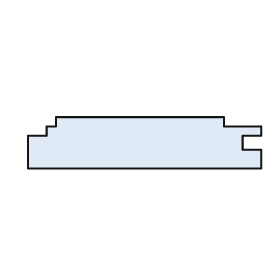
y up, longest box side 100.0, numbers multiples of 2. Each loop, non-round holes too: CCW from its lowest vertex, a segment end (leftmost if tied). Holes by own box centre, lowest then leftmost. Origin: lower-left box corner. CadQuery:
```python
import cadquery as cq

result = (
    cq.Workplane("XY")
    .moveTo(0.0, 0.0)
    .lineTo(100.0, 0.0)
    .lineTo(100.0, 8.0)
    .lineTo(92.0, 8.0)
    .lineTo(92.0, 14.0)
    .lineTo(100.0, 14.0)
    .lineTo(100.0, 18.0)
    .lineTo(84.0, 18.0)
    .lineTo(84.0, 22.0)
    .lineTo(12.0, 22.0)
    .lineTo(12.0, 18.0)
    .lineTo(8.0, 18.0)
    .lineTo(8.0, 14.0)
    .lineTo(0.0, 14.0)
    .close()
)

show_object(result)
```